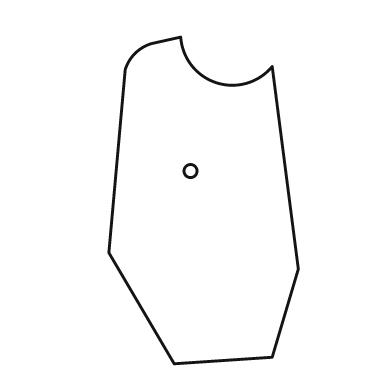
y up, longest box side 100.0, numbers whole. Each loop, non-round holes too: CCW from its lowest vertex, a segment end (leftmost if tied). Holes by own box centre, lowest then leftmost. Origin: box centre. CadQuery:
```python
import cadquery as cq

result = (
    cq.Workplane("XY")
    .moveTo(-9.0, -50.0)
    .lineTo(21.0, -48.0)
    .lineTo(29.0, -21.0)
    .lineTo(21.0, 41.0)
    .threePointArc((4.0, 36.0), (-7.0, 50.0))
    .lineTo(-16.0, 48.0)
    .threePointArc((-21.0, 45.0), (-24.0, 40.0))
    .lineTo(-29.0, -16.0)
    .close()
    .moveTo(-4.0, 9.0)
    .circle(2.0)
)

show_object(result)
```